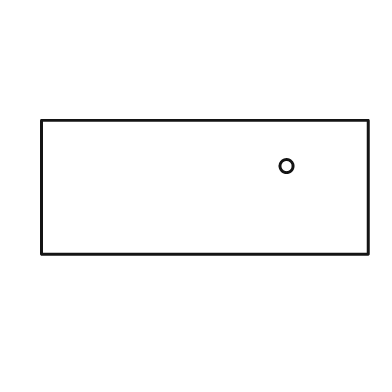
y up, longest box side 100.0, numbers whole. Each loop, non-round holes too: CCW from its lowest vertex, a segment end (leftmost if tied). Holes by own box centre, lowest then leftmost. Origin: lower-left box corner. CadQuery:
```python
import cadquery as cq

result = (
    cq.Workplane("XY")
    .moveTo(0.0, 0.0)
    .lineTo(100.0, 0.0)
    .lineTo(100.0, 41.0)
    .lineTo(0.0, 41.0)
    .close()
    .moveTo(75.0, 27.0)
    .circle(2.0)
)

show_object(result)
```